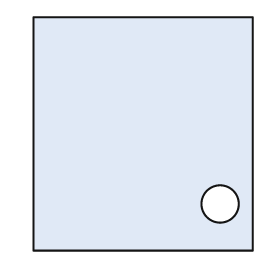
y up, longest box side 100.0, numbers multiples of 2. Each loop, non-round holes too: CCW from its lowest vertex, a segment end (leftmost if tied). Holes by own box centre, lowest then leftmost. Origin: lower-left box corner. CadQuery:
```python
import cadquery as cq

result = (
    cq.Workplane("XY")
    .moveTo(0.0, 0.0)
    .lineTo(94.0, 0.0)
    .lineTo(94.0, 100.0)
    .lineTo(0.0, 100.0)
    .close()
    .moveTo(80.0, 20.0)
    .circle(8.0)
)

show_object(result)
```